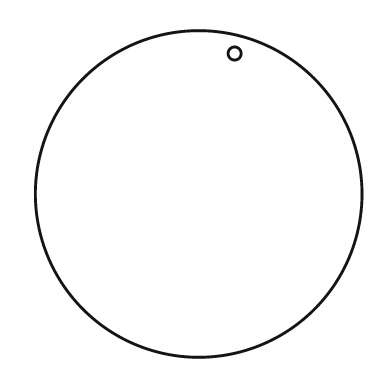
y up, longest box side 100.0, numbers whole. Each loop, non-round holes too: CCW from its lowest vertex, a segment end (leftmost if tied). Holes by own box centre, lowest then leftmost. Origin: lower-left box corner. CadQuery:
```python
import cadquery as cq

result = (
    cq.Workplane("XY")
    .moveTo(50.0, 50.0)
    .circle(50.0)
    .moveTo(61.0, 93.0)
    .circle(2.0)
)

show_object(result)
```